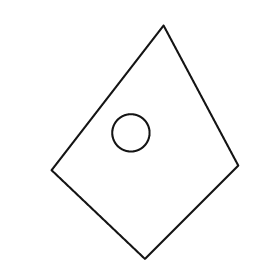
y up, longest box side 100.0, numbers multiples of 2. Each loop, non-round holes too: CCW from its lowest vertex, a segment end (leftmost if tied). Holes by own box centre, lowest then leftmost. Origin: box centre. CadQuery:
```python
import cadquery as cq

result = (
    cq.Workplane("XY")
    .moveTo(0.0, -50.0)
    .lineTo(40.0, -10.0)
    .lineTo(8.0, 50.0)
    .lineTo(-40.0, -12.0)
    .close()
    .moveTo(-6.0, 4.0)
    .circle(8.0)
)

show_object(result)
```